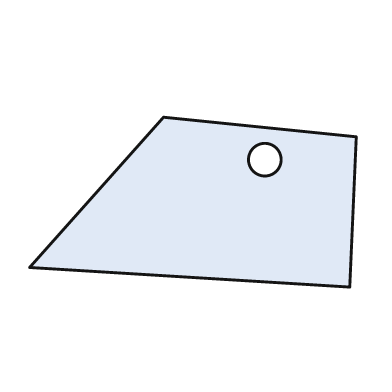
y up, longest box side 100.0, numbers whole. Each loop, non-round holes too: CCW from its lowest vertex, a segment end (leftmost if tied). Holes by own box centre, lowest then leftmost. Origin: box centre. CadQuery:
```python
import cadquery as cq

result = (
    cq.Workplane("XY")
    .moveTo(48.0, -26.0)
    .lineTo(50.0, 20.0)
    .lineTo(-9.0, 26.0)
    .lineTo(-50.0, -20.0)
    .close()
    .moveTo(22.0, 13.0)
    .circle(5.0)
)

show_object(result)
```